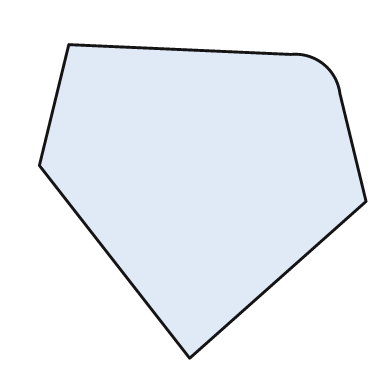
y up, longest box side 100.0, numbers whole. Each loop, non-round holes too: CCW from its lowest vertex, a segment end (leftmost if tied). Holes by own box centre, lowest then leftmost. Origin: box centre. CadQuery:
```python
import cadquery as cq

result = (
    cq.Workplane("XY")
    .moveTo(-4.0, -48.0)
    .lineTo(50.0, 0.0)
    .lineTo(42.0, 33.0)
    .threePointArc((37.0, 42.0), (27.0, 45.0))
    .lineTo(-41.0, 48.0)
    .lineTo(-50.0, 11.0)
    .close()
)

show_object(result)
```